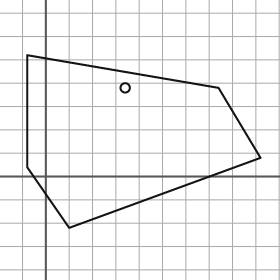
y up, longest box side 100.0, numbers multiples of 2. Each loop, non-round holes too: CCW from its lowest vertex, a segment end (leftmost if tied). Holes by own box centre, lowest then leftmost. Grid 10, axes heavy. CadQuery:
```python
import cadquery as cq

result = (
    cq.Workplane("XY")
    .moveTo(10.0, -22.0)
    .lineTo(92.0, 8.0)
    .lineTo(74.0, 38.0)
    .lineTo(-8.0, 52.0)
    .lineTo(-8.0, 4.0)
    .close()
    .moveTo(34.0, 38.0)
    .circle(2.0)
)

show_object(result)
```